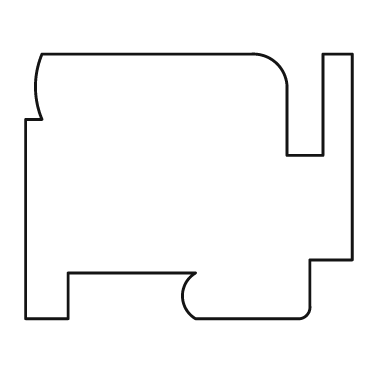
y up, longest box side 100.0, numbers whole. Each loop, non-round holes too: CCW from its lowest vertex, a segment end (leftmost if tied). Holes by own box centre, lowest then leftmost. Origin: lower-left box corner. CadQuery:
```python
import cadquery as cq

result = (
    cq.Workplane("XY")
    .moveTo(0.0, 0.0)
    .lineTo(13.0, 0.0)
    .lineTo(13.0, 14.0)
    .lineTo(52.0, 14.0)
    .threePointArc((48.0, 7.0), (52.0, 0.0))
    .lineTo(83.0, 0.0)
    .threePointArc((86.0, 1.0), (87.0, 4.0))
    .lineTo(87.0, 18.0)
    .lineTo(100.0, 18.0)
    .lineTo(100.0, 81.0)
    .lineTo(91.0, 81.0)
    .lineTo(91.0, 50.0)
    .lineTo(80.0, 50.0)
    .lineTo(80.0, 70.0)
    .threePointArc((77.0, 78.0), (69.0, 81.0))
    .lineTo(5.0, 81.0)
    .threePointArc((3.0, 71.0), (5.0, 61.0))
    .lineTo(0.0, 61.0)
    .close()
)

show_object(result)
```